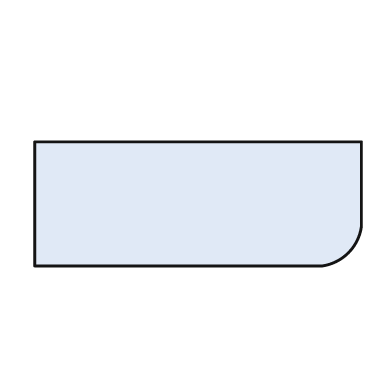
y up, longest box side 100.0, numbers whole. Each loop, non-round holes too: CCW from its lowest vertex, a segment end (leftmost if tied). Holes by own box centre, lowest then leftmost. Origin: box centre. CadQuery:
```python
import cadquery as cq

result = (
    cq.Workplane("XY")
    .moveTo(-50.0, -19.0)
    .lineTo(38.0, -19.0)
    .threePointArc((46.0, -15.0), (50.0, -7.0))
    .lineTo(50.0, 19.0)
    .lineTo(-50.0, 19.0)
    .close()
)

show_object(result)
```